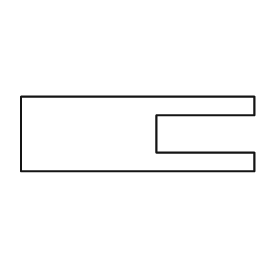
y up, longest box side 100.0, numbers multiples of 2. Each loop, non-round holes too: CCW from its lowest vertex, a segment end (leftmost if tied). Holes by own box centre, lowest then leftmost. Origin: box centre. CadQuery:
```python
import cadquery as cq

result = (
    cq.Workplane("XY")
    .moveTo(-50.0, -16.0)
    .lineTo(50.0, -16.0)
    .lineTo(50.0, -8.0)
    .lineTo(8.0, -8.0)
    .lineTo(8.0, 8.0)
    .lineTo(50.0, 8.0)
    .lineTo(50.0, 16.0)
    .lineTo(-50.0, 16.0)
    .close()
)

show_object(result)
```